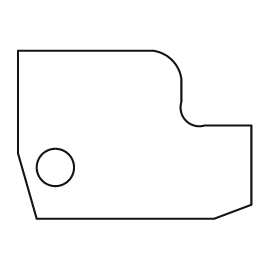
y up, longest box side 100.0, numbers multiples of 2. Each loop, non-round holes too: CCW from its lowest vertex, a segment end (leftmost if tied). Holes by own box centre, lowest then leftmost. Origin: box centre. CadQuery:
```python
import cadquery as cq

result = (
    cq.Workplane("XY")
    .moveTo(-42.0, -36.0)
    .lineTo(34.0, -36.0)
    .lineTo(50.0, -30.0)
    .lineTo(50.0, 4.0)
    .lineTo(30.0, 4.0)
    .threePointArc((22.0, 6.0), (20.0, 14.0))
    .lineTo(20.0, 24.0)
    .threePointArc((16.0, 32.0), (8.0, 36.0))
    .lineTo(-50.0, 36.0)
    .lineTo(-50.0, -8.0)
    .close()
    .moveTo(-34.0, -14.0)
    .circle(8.0)
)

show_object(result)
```